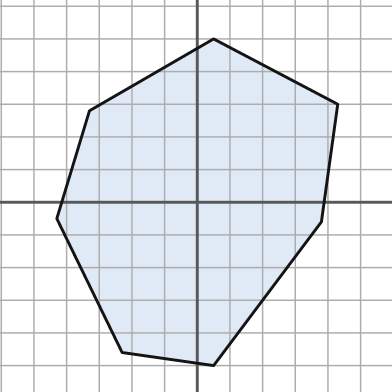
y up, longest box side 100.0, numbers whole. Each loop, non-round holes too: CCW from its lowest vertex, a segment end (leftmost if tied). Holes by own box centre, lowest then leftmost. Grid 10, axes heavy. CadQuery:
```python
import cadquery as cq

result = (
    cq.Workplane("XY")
    .moveTo(5.0, -50.0)
    .lineTo(38.0, -6.0)
    .lineTo(43.0, 30.0)
    .lineTo(5.0, 50.0)
    .lineTo(-33.0, 28.0)
    .lineTo(-43.0, -5.0)
    .lineTo(-23.0, -46.0)
    .close()
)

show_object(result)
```